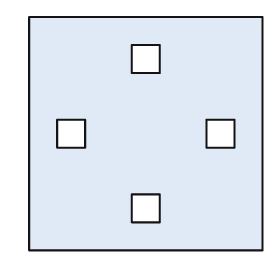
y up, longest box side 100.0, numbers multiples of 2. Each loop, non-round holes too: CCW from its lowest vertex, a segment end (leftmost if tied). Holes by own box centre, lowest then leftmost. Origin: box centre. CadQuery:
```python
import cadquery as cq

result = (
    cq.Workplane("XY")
    .moveTo(-50.0, -50.0)
    .lineTo(50.0, -50.0)
    .lineTo(50.0, 50.0)
    .lineTo(-50.0, 50.0)
    .close()
    .moveTo(-6.0, -38.0)
    .lineTo(6.0, -38.0)
    .lineTo(6.0, -26.0)
    .lineTo(-6.0, -26.0)
    .close()
    .moveTo(-38.0, -6.0)
    .lineTo(-26.0, -6.0)
    .lineTo(-26.0, 6.0)
    .lineTo(-38.0, 6.0)
    .close()
    .moveTo(26.0, -6.0)
    .lineTo(38.0, -6.0)
    .lineTo(38.0, 6.0)
    .lineTo(26.0, 6.0)
    .close()
    .moveTo(-6.0, 26.0)
    .lineTo(6.0, 26.0)
    .lineTo(6.0, 38.0)
    .lineTo(-6.0, 38.0)
    .close()
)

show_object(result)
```